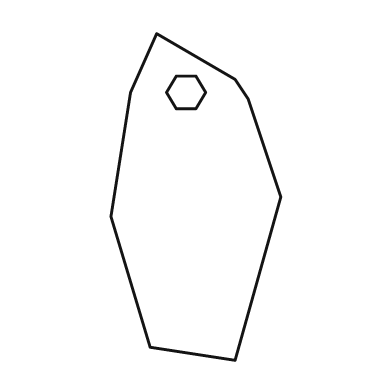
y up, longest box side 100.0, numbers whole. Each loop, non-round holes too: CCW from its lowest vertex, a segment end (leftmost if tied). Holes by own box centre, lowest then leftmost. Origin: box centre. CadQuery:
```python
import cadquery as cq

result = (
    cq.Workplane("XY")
    .moveTo(12.0, -50.0)
    .lineTo(26.0, 0.0)
    .lineTo(16.0, 30.0)
    .lineTo(12.0, 36.0)
    .lineTo(-12.0, 50.0)
    .lineTo(-20.0, 32.0)
    .lineTo(-26.0, -6.0)
    .lineTo(-14.0, -46.0)
    .close()
    .moveTo(-6.0, 27.0)
    .lineTo(0.0, 27.0)
    .lineTo(3.0, 32.0)
    .lineTo(0.0, 37.0)
    .lineTo(-6.0, 37.0)
    .lineTo(-9.0, 32.0)
    .close()
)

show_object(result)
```